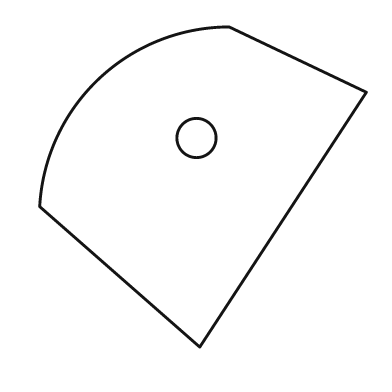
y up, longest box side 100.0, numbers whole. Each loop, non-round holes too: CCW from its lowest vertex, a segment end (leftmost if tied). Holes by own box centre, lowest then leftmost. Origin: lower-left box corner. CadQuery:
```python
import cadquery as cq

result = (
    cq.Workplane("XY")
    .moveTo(49.0, 0.0)
    .lineTo(100.0, 78.0)
    .lineTo(58.0, 98.0)
    .threePointArc((18.0, 82.0), (0.0, 43.0))
    .close()
    .moveTo(48.0, 64.0)
    .circle(6.0)
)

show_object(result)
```